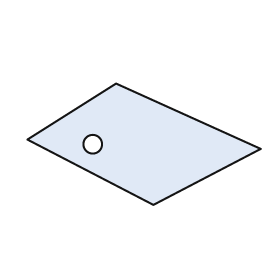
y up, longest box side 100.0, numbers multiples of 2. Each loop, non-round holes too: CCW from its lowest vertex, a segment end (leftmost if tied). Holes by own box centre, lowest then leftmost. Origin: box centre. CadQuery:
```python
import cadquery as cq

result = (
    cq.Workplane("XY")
    .moveTo(4.0, -26.0)
    .lineTo(50.0, -2.0)
    .lineTo(-12.0, 26.0)
    .lineTo(-50.0, 2.0)
    .close()
    .moveTo(-22.0, 0.0)
    .circle(4.0)
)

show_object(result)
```